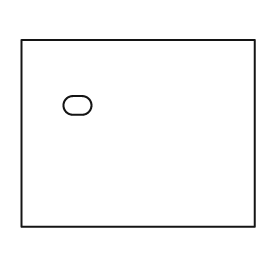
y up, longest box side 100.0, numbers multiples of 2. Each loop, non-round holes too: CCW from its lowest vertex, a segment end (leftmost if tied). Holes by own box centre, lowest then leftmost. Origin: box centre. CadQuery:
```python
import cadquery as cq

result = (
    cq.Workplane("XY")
    .moveTo(-50.0, -40.0)
    .lineTo(50.0, -40.0)
    .lineTo(50.0, 40.0)
    .lineTo(-50.0, 40.0)
    .close()
    .moveTo(-28.0, 8.0)
    .lineTo(-24.0, 8.0)
    .threePointArc((-20.0, 12.0), (-24.0, 16.0))
    .lineTo(-28.0, 16.0)
    .threePointArc((-32.0, 12.0), (-28.0, 8.0))
    .close()
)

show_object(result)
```